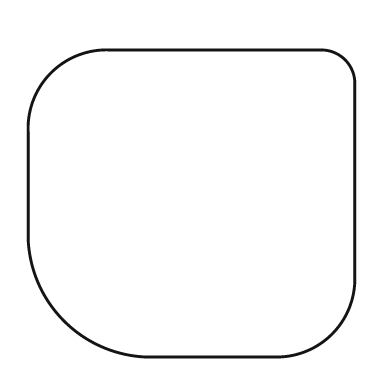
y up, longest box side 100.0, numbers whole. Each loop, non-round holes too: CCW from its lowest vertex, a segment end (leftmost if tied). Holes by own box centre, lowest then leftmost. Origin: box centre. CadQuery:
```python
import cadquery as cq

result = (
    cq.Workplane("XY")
    .moveTo(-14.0, -47.0)
    .lineTo(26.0, -47.0)
    .threePointArc((43.0, -40.0), (50.0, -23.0))
    .lineTo(50.0, 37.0)
    .threePointArc((47.0, 44.0), (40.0, 47.0))
    .lineTo(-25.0, 47.0)
    .threePointArc((-43.0, 40.0), (-50.0, 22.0))
    .lineTo(-50.0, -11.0)
    .threePointArc((-39.0, -36.0), (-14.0, -47.0))
    .close()
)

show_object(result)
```